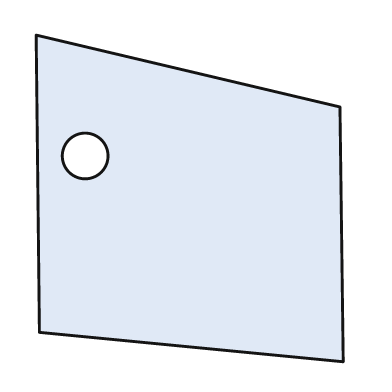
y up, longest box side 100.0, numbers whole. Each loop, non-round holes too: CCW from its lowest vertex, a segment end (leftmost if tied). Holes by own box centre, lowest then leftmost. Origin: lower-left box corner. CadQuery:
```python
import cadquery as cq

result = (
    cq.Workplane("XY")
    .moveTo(94.0, 0.0)
    .lineTo(93.0, 78.0)
    .lineTo(0.0, 100.0)
    .lineTo(1.0, 9.0)
    .close()
    .moveTo(15.0, 63.0)
    .circle(7.0)
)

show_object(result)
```